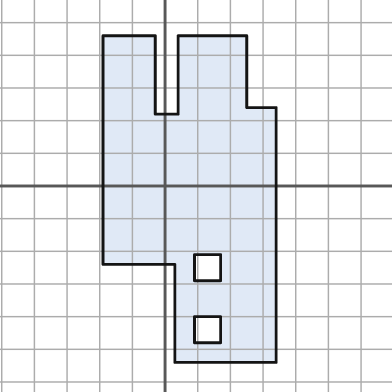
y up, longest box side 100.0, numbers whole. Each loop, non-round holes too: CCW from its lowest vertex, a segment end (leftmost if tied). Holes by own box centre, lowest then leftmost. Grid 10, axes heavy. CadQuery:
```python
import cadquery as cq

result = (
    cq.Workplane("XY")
    .moveTo(3.0, -54.0)
    .lineTo(34.0, -54.0)
    .lineTo(34.0, 24.0)
    .lineTo(25.0, 24.0)
    .lineTo(25.0, 46.0)
    .lineTo(4.0, 46.0)
    .lineTo(4.0, 22.0)
    .lineTo(-3.0, 22.0)
    .lineTo(-3.0, 46.0)
    .lineTo(-19.0, 46.0)
    .lineTo(-19.0, -24.0)
    .lineTo(3.0, -24.0)
    .close()
    .moveTo(9.0, -48.0)
    .lineTo(17.0, -48.0)
    .lineTo(17.0, -40.0)
    .lineTo(9.0, -40.0)
    .close()
    .moveTo(9.0, -29.0)
    .lineTo(17.0, -29.0)
    .lineTo(17.0, -21.0)
    .lineTo(9.0, -21.0)
    .close()
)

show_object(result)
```